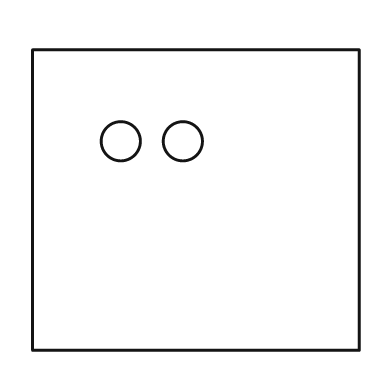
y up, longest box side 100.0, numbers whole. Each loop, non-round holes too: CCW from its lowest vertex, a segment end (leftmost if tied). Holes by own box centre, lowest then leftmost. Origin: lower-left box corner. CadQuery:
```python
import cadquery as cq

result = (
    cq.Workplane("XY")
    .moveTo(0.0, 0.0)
    .lineTo(100.0, 0.0)
    .lineTo(100.0, 92.0)
    .lineTo(0.0, 92.0)
    .close()
    .moveTo(27.0, 64.0)
    .circle(6.0)
    .moveTo(46.0, 64.0)
    .circle(6.0)
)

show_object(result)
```